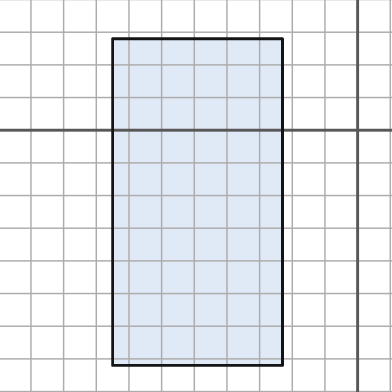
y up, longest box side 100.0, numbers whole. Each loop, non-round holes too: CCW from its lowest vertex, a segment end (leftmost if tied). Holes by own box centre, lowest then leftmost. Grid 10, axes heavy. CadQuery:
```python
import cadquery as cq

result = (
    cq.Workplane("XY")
    .moveTo(-75.0, -72.0)
    .lineTo(-23.0, -72.0)
    .lineTo(-23.0, 28.0)
    .lineTo(-75.0, 28.0)
    .close()
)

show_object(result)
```